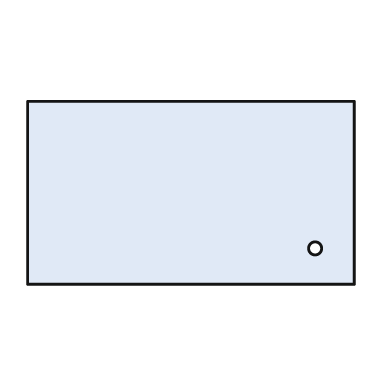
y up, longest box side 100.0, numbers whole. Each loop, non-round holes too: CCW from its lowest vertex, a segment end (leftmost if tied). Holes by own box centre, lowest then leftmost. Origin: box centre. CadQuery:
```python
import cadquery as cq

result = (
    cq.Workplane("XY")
    .moveTo(-50.0, -28.0)
    .lineTo(50.0, -28.0)
    .lineTo(50.0, 28.0)
    .lineTo(-50.0, 28.0)
    .close()
    .moveTo(38.0, -17.0)
    .circle(2.0)
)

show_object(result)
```